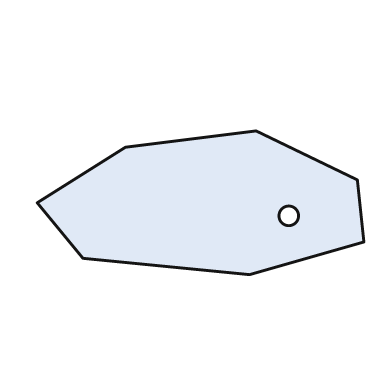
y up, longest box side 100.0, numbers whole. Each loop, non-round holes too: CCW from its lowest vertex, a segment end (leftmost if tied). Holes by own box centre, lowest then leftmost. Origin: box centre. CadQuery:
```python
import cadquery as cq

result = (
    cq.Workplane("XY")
    .moveTo(15.0, -22.0)
    .lineTo(50.0, -12.0)
    .lineTo(48.0, 7.0)
    .lineTo(17.0, 22.0)
    .lineTo(-23.0, 17.0)
    .lineTo(-50.0, 0.0)
    .lineTo(-36.0, -17.0)
    .close()
    .moveTo(27.0, -4.0)
    .circle(3.0)
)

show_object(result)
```